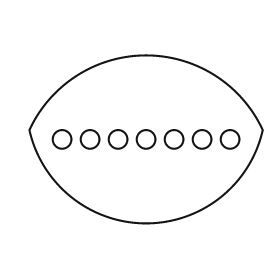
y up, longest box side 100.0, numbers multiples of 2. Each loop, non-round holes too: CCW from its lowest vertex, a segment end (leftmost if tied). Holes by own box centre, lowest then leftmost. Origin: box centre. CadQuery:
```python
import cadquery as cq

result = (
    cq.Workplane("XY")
    .moveTo(-50.0, 4.0)
    .threePointArc((0.0, -36.0), (50.0, 4.0))
    .threePointArc((0.0, 36.0), (-50.0, 4.0))
    .close()
    .moveTo(-36.0, 0.0)
    .circle(4.0)
    .moveTo(-24.0, 0.0)
    .circle(4.0)
    .moveTo(-12.0, 0.0)
    .circle(4.0)
    .moveTo(0.0, 0.0)
    .circle(4.0)
    .moveTo(12.0, 0.0)
    .circle(4.0)
    .moveTo(24.0, 0.0)
    .circle(4.0)
    .moveTo(36.0, 0.0)
    .circle(4.0)
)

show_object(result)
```